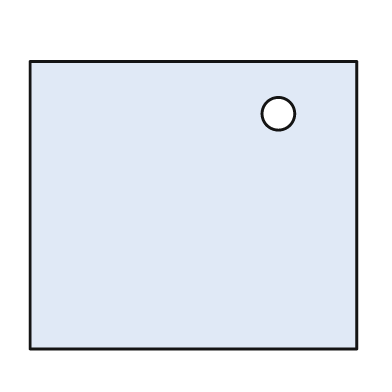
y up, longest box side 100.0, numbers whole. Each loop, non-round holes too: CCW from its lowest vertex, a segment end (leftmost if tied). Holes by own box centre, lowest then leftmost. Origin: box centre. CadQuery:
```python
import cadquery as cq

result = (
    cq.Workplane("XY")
    .moveTo(-50.0, -44.0)
    .lineTo(50.0, -44.0)
    .lineTo(50.0, 44.0)
    .lineTo(-50.0, 44.0)
    .close()
    .moveTo(26.0, 28.0)
    .circle(5.0)
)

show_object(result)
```